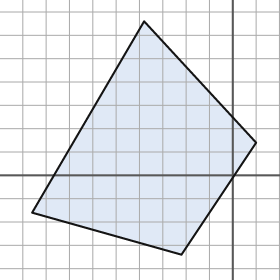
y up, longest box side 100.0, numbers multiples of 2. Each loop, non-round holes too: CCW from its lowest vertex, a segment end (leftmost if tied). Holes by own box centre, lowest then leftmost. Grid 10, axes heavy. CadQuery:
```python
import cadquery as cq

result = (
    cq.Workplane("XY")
    .moveTo(-22.0, -34.0)
    .lineTo(10.0, 14.0)
    .lineTo(-38.0, 66.0)
    .lineTo(-86.0, -16.0)
    .close()
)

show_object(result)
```